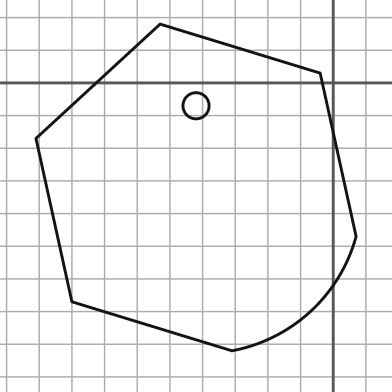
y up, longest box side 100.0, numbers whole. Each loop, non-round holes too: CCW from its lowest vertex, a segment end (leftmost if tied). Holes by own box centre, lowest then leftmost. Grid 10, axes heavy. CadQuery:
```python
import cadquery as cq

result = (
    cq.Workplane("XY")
    .moveTo(-31.0, -82.0)
    .threePointArc((-7.0, -70.0), (7.0, -47.0))
    .lineTo(-4.0, 3.0)
    .lineTo(-53.0, 18.0)
    .lineTo(-91.0, -17.0)
    .lineTo(-80.0, -67.0)
    .close()
    .moveTo(-42.0, -7.0)
    .circle(4.0)
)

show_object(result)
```